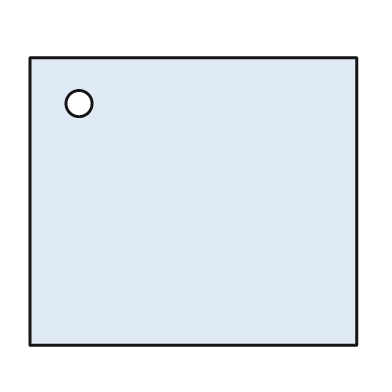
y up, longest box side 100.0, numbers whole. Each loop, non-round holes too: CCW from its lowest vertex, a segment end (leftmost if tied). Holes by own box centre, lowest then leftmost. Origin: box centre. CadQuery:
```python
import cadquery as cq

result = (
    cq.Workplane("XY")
    .moveTo(-50.0, -44.0)
    .lineTo(50.0, -44.0)
    .lineTo(50.0, 44.0)
    .lineTo(-50.0, 44.0)
    .close()
    .moveTo(-35.0, 30.0)
    .circle(4.0)
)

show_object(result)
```